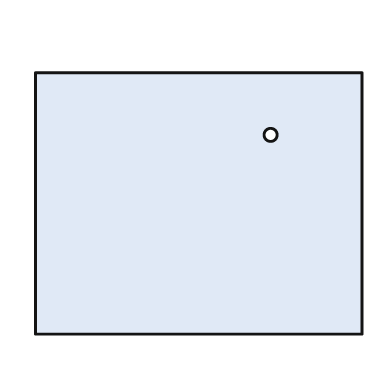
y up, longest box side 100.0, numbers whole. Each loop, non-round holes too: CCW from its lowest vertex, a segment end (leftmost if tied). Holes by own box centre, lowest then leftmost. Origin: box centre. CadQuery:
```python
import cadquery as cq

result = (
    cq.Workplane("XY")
    .moveTo(-50.0, -40.0)
    .lineTo(50.0, -40.0)
    .lineTo(50.0, 40.0)
    .lineTo(-50.0, 40.0)
    .close()
    .moveTo(22.0, 21.0)
    .circle(2.0)
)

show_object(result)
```